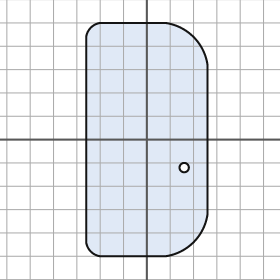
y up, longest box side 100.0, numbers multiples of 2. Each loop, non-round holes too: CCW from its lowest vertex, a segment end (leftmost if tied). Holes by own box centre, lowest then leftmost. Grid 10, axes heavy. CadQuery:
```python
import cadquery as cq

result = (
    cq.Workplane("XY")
    .moveTo(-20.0, -50.0)
    .lineTo(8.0, -50.0)
    .threePointArc((20.0, -44.0), (26.0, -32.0))
    .lineTo(26.0, 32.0)
    .threePointArc((20.0, 44.0), (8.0, 50.0))
    .lineTo(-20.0, 50.0)
    .threePointArc((-24.0, 48.0), (-26.0, 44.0))
    .lineTo(-26.0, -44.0)
    .threePointArc((-24.0, -48.0), (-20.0, -50.0))
    .close()
    .moveTo(16.0, -12.0)
    .circle(2.0)
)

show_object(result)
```